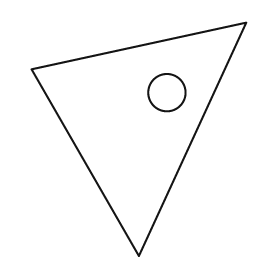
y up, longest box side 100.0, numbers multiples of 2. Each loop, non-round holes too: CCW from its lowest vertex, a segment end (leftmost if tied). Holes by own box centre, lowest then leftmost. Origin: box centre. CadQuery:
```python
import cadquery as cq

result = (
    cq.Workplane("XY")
    .moveTo(0.0, -50.0)
    .lineTo(46.0, 50.0)
    .lineTo(-46.0, 30.0)
    .close()
    .moveTo(12.0, 20.0)
    .circle(8.0)
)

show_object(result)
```